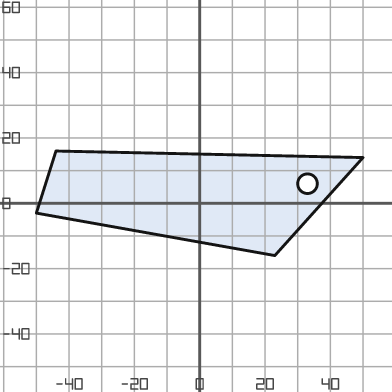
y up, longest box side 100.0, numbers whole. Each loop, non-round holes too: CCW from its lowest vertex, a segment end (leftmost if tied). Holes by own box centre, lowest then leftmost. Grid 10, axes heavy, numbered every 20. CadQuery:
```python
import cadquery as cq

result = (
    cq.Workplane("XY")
    .moveTo(23.0, -16.0)
    .lineTo(50.0, 14.0)
    .lineTo(-44.0, 16.0)
    .lineTo(-50.0, -3.0)
    .close()
    .moveTo(33.0, 6.0)
    .circle(3.0)
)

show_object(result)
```